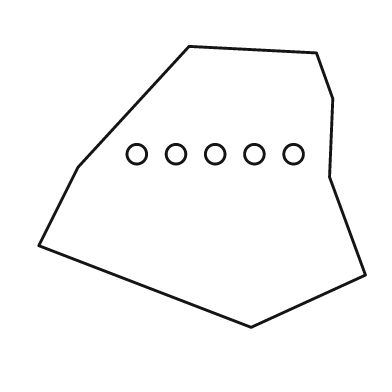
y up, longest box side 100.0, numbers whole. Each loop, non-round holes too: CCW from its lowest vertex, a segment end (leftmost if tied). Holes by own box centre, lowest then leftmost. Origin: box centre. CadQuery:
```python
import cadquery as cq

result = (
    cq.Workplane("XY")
    .moveTo(15.0, -43.0)
    .lineTo(50.0, -27.0)
    .lineTo(39.0, 3.0)
    .lineTo(40.0, 27.0)
    .lineTo(35.0, 41.0)
    .lineTo(-4.0, 43.0)
    .lineTo(-38.0, 6.0)
    .lineTo(-50.0, -18.0)
    .close()
    .moveTo(-20.0, 10.0)
    .circle(3.0)
    .moveTo(-8.0, 10.0)
    .circle(3.0)
    .moveTo(4.0, 10.0)
    .circle(3.0)
    .moveTo(16.0, 10.0)
    .circle(3.0)
    .moveTo(28.0, 10.0)
    .circle(3.0)
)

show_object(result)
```